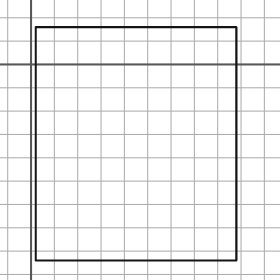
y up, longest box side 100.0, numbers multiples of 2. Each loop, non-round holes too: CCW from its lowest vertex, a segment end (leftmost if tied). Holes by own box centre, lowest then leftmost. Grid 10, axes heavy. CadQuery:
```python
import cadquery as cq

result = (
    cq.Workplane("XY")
    .moveTo(2.0, -84.0)
    .lineTo(88.0, -84.0)
    .lineTo(88.0, 16.0)
    .lineTo(2.0, 16.0)
    .close()
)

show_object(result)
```